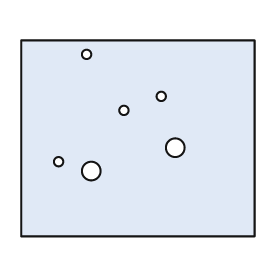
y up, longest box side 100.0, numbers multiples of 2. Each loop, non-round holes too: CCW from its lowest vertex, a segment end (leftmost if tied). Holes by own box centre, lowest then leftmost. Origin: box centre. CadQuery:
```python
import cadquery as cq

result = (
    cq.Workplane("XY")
    .moveTo(-50.0, -42.0)
    .lineTo(50.0, -42.0)
    .lineTo(50.0, 42.0)
    .lineTo(-50.0, 42.0)
    .close()
    .moveTo(-20.0, -14.0)
    .circle(4.0)
    .moveTo(-34.0, -10.0)
    .circle(2.0)
    .moveTo(16.0, -4.0)
    .circle(4.0)
    .moveTo(-6.0, 12.0)
    .circle(2.0)
    .moveTo(10.0, 18.0)
    .circle(2.0)
    .moveTo(-22.0, 36.0)
    .circle(2.0)
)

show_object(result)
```